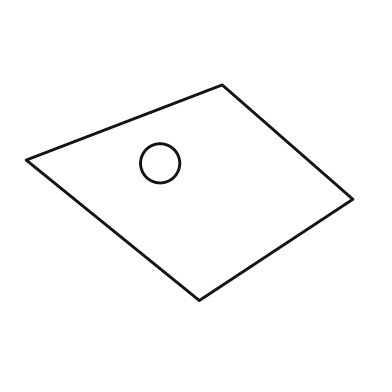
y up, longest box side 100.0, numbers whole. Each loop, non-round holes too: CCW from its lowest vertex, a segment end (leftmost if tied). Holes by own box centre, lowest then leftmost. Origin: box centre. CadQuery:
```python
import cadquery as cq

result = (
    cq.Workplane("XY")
    .moveTo(3.0, -33.0)
    .lineTo(50.0, -2.0)
    .lineTo(10.0, 33.0)
    .lineTo(-50.0, 10.0)
    .close()
    .moveTo(-9.0, 9.0)
    .circle(6.0)
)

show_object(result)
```